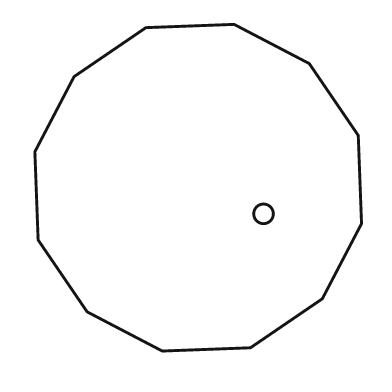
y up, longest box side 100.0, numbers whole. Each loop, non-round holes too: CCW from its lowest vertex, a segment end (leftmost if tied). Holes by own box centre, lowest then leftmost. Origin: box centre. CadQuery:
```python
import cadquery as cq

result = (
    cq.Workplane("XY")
    .moveTo(-11.0, -50.0)
    .lineTo(16.0, -49.0)
    .lineTo(38.0, -34.0)
    .lineTo(50.0, -11.0)
    .lineTo(49.0, 16.0)
    .lineTo(34.0, 38.0)
    .lineTo(11.0, 50.0)
    .lineTo(-16.0, 49.0)
    .lineTo(-38.0, 34.0)
    .lineTo(-50.0, 11.0)
    .lineTo(-49.0, -16.0)
    .lineTo(-34.0, -38.0)
    .close()
    .moveTo(20.0, -8.0)
    .circle(3.0)
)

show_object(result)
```